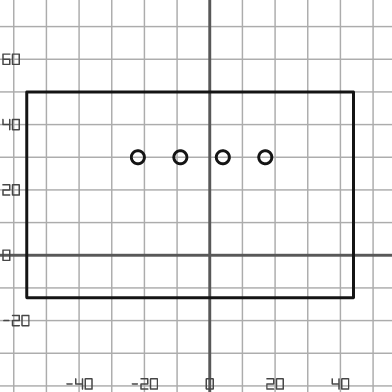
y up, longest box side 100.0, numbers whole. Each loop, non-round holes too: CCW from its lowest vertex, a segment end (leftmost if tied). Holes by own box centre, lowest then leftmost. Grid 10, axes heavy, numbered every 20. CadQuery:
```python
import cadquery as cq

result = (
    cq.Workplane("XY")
    .moveTo(-56.0, -13.0)
    .lineTo(44.0, -13.0)
    .lineTo(44.0, 50.0)
    .lineTo(-56.0, 50.0)
    .close()
    .moveTo(-22.0, 30.0)
    .circle(2.0)
    .moveTo(-9.0, 30.0)
    .circle(2.0)
    .moveTo(4.0, 30.0)
    .circle(2.0)
    .moveTo(17.0, 30.0)
    .circle(2.0)
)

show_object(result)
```